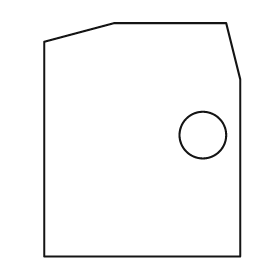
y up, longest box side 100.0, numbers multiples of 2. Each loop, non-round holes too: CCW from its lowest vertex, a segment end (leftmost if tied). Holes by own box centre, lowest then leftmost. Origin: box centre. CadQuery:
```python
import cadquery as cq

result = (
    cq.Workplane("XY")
    .moveTo(-42.0, -50.0)
    .lineTo(42.0, -50.0)
    .lineTo(42.0, 26.0)
    .lineTo(36.0, 50.0)
    .lineTo(-12.0, 50.0)
    .lineTo(-42.0, 42.0)
    .close()
    .moveTo(26.0, 2.0)
    .circle(10.0)
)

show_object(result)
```